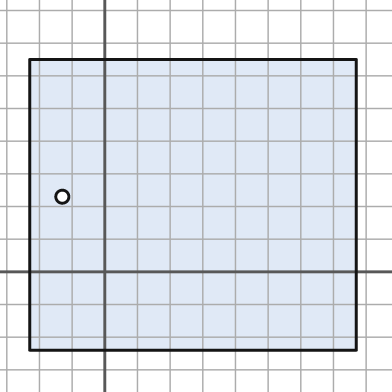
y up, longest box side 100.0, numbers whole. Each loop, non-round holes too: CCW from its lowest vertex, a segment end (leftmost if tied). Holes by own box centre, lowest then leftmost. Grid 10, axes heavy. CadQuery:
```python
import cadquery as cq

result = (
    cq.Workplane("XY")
    .moveTo(-23.0, -24.0)
    .lineTo(77.0, -24.0)
    .lineTo(77.0, 65.0)
    .lineTo(-23.0, 65.0)
    .close()
    .moveTo(-13.0, 23.0)
    .circle(2.0)
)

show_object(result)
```